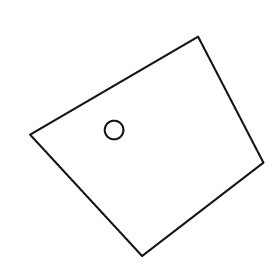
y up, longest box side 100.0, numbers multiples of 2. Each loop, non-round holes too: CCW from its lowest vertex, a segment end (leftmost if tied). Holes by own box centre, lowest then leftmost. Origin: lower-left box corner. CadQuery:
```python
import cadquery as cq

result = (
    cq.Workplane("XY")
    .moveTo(48.0, 0.0)
    .lineTo(100.0, 40.0)
    .lineTo(72.0, 94.0)
    .lineTo(0.0, 52.0)
    .close()
    .moveTo(36.0, 54.0)
    .circle(4.0)
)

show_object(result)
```